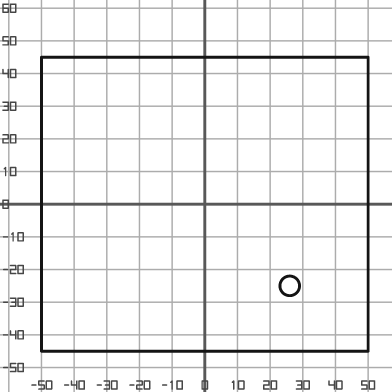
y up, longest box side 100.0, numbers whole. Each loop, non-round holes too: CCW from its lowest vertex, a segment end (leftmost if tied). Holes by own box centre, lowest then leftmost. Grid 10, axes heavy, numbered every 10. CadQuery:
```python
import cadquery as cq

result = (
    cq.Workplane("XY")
    .moveTo(-50.0, -45.0)
    .lineTo(50.0, -45.0)
    .lineTo(50.0, 45.0)
    .lineTo(-50.0, 45.0)
    .close()
    .moveTo(26.0, -25.0)
    .circle(3.0)
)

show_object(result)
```